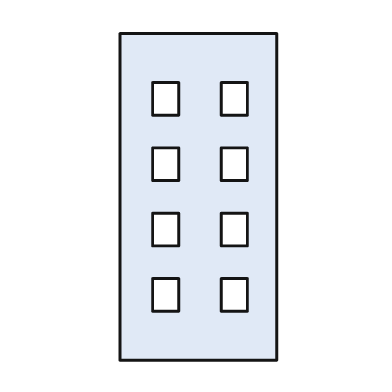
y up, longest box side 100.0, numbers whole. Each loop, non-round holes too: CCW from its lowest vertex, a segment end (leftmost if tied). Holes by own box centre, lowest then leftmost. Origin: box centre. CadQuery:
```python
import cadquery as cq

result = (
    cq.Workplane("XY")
    .moveTo(-24.0, -50.0)
    .lineTo(24.0, -50.0)
    .lineTo(24.0, 50.0)
    .lineTo(-24.0, 50.0)
    .close()
    .moveTo(-14.0, -35.0)
    .lineTo(-6.0, -35.0)
    .lineTo(-6.0, -25.0)
    .lineTo(-14.0, -25.0)
    .close()
    .moveTo(7.0, -35.0)
    .lineTo(15.0, -35.0)
    .lineTo(15.0, -25.0)
    .lineTo(7.0, -25.0)
    .close()
    .moveTo(-14.0, -15.0)
    .lineTo(-6.0, -15.0)
    .lineTo(-6.0, -5.0)
    .lineTo(-14.0, -5.0)
    .close()
    .moveTo(7.0, -15.0)
    .lineTo(15.0, -15.0)
    .lineTo(15.0, -5.0)
    .lineTo(7.0, -5.0)
    .close()
    .moveTo(-14.0, 5.0)
    .lineTo(-6.0, 5.0)
    .lineTo(-6.0, 15.0)
    .lineTo(-14.0, 15.0)
    .close()
    .moveTo(7.0, 5.0)
    .lineTo(15.0, 5.0)
    .lineTo(15.0, 15.0)
    .lineTo(7.0, 15.0)
    .close()
    .moveTo(-14.0, 25.0)
    .lineTo(-6.0, 25.0)
    .lineTo(-6.0, 35.0)
    .lineTo(-14.0, 35.0)
    .close()
    .moveTo(7.0, 25.0)
    .lineTo(15.0, 25.0)
    .lineTo(15.0, 35.0)
    .lineTo(7.0, 35.0)
    .close()
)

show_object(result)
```